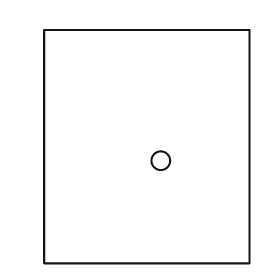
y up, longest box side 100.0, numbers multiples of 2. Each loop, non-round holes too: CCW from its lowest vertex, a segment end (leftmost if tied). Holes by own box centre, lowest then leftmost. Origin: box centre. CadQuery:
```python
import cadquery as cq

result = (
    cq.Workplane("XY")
    .moveTo(-44.0, -50.0)
    .lineTo(44.0, -50.0)
    .lineTo(44.0, 50.0)
    .lineTo(-44.0, 50.0)
    .close()
    .moveTo(6.0, -6.0)
    .circle(4.0)
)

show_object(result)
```